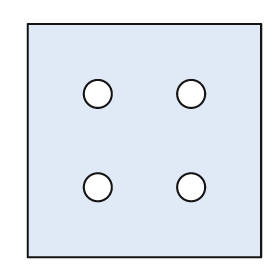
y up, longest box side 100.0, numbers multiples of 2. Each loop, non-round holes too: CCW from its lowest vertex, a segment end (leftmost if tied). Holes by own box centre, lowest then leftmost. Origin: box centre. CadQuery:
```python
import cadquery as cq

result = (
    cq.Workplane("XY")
    .moveTo(-50.0, -50.0)
    .lineTo(50.0, -50.0)
    .lineTo(50.0, 50.0)
    .lineTo(-50.0, 50.0)
    .close()
    .moveTo(-20.0, -20.0)
    .circle(6.0)
    .moveTo(20.0, -20.0)
    .circle(6.0)
    .moveTo(-20.0, 20.0)
    .circle(6.0)
    .moveTo(20.0, 20.0)
    .circle(6.0)
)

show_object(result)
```